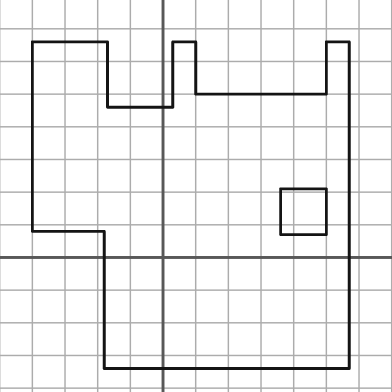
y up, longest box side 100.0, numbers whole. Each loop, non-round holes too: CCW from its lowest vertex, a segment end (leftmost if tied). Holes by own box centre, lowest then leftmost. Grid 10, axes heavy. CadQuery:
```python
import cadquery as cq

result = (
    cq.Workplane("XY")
    .moveTo(-18.0, -34.0)
    .lineTo(57.0, -34.0)
    .lineTo(57.0, 66.0)
    .lineTo(50.0, 66.0)
    .lineTo(50.0, 50.0)
    .lineTo(10.0, 50.0)
    .lineTo(10.0, 66.0)
    .lineTo(3.0, 66.0)
    .lineTo(3.0, 46.0)
    .lineTo(-17.0, 46.0)
    .lineTo(-17.0, 66.0)
    .lineTo(-40.0, 66.0)
    .lineTo(-40.0, 8.0)
    .lineTo(-18.0, 8.0)
    .close()
    .moveTo(36.0, 7.0)
    .lineTo(50.0, 7.0)
    .lineTo(50.0, 21.0)
    .lineTo(36.0, 21.0)
    .close()
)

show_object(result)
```